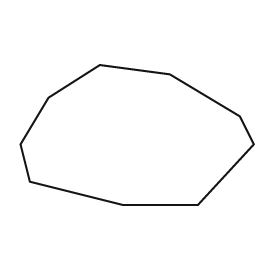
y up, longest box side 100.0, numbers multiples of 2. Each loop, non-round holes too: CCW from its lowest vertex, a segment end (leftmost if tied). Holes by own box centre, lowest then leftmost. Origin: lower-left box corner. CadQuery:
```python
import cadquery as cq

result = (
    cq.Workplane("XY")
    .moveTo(44.0, 0.0)
    .lineTo(76.0, 0.0)
    .lineTo(100.0, 26.0)
    .lineTo(94.0, 38.0)
    .lineTo(64.0, 56.0)
    .lineTo(34.0, 60.0)
    .lineTo(12.0, 46.0)
    .lineTo(0.0, 26.0)
    .lineTo(4.0, 10.0)
    .close()
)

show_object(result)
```